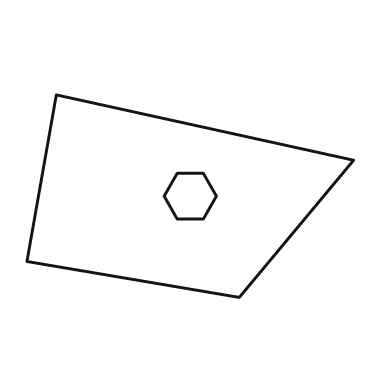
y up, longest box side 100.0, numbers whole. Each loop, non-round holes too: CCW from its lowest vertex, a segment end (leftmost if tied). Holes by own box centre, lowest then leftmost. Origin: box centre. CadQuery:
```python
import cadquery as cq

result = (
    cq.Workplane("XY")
    .moveTo(15.0, -31.0)
    .lineTo(50.0, 11.0)
    .lineTo(-41.0, 31.0)
    .lineTo(-50.0, -20.0)
    .close()
    .moveTo(-4.0, -7.0)
    .lineTo(4.0, -7.0)
    .lineTo(8.0, 0.0)
    .lineTo(4.0, 7.0)
    .lineTo(-4.0, 7.0)
    .lineTo(-8.0, 0.0)
    .close()
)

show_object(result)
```